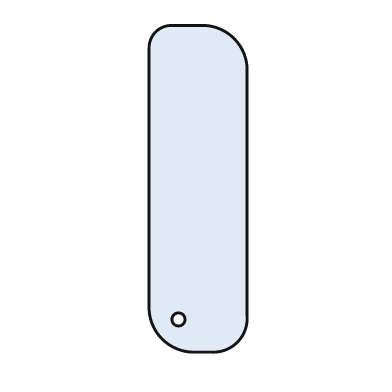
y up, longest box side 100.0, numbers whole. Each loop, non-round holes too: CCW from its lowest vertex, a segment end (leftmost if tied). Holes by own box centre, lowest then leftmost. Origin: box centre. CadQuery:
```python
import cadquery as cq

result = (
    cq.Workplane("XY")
    .moveTo(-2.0, -50.0)
    .lineTo(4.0, -50.0)
    .threePointArc((12.0, -47.0), (15.0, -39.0))
    .lineTo(15.0, 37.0)
    .threePointArc((11.0, 46.0), (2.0, 50.0))
    .lineTo(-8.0, 50.0)
    .threePointArc((-13.0, 48.0), (-15.0, 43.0))
    .lineTo(-15.0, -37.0)
    .threePointArc((-11.0, -46.0), (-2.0, -50.0))
    .close()
    .moveTo(-6.0, -40.0)
    .circle(2.0)
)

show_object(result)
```